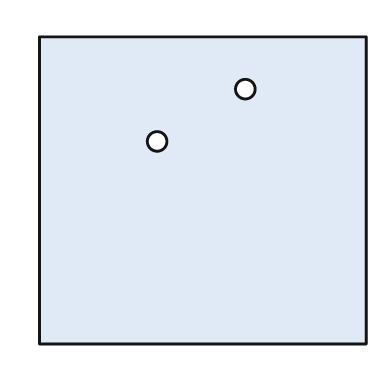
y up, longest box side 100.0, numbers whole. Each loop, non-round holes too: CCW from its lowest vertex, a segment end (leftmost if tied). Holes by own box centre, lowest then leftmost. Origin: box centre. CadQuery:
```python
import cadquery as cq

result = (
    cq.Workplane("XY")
    .moveTo(-50.0, -47.0)
    .lineTo(50.0, -47.0)
    .lineTo(50.0, 47.0)
    .lineTo(-50.0, 47.0)
    .close()
    .moveTo(-14.0, 15.0)
    .circle(3.0)
    .moveTo(13.0, 31.0)
    .circle(3.0)
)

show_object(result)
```